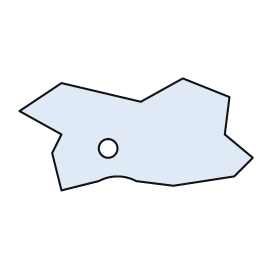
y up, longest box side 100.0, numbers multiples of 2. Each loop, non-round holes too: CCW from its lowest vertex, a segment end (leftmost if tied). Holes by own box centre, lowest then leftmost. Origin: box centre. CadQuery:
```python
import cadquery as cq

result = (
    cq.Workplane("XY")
    .moveTo(-32.0, -24.0)
    .lineTo(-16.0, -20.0)
    .threePointArc((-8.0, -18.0), (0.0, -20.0))
    .lineTo(16.0, -22.0)
    .lineTo(42.0, -18.0)
    .lineTo(50.0, -10.0)
    .lineTo(38.0, 0.0)
    .lineTo(40.0, 16.0)
    .lineTo(20.0, 24.0)
    .lineTo(2.0, 14.0)
    .lineTo(-32.0, 22.0)
    .lineTo(-50.0, 10.0)
    .lineTo(-32.0, 0.0)
    .lineTo(-36.0, -8.0)
    .close()
    .moveTo(-12.0, -6.0)
    .circle(4.0)
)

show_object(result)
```